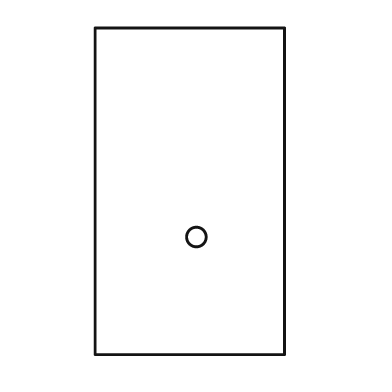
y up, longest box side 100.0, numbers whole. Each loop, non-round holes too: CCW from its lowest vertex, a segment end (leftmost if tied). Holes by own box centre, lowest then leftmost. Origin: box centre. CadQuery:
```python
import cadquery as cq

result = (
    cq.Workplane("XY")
    .moveTo(-29.0, -50.0)
    .lineTo(29.0, -50.0)
    .lineTo(29.0, 50.0)
    .lineTo(-29.0, 50.0)
    .close()
    .moveTo(2.0, -14.0)
    .circle(3.0)
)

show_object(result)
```